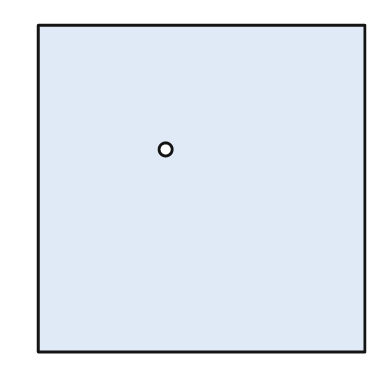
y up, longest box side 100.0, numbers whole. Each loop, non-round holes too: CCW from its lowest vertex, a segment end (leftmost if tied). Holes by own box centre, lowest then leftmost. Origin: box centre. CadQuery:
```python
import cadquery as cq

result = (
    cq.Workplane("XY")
    .moveTo(-50.0, -50.0)
    .lineTo(50.0, -50.0)
    .lineTo(50.0, 50.0)
    .lineTo(-50.0, 50.0)
    .close()
    .moveTo(-11.0, 12.0)
    .circle(2.0)
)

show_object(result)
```